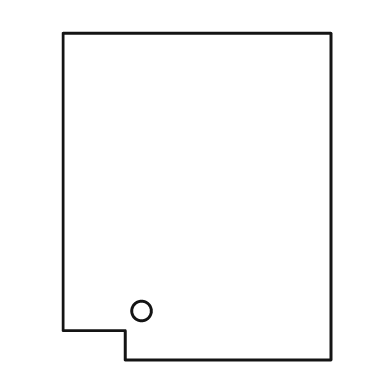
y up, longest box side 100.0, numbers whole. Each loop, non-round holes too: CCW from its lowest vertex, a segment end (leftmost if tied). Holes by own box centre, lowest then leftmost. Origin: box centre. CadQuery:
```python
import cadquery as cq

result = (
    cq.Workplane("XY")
    .moveTo(-22.0, -50.0)
    .lineTo(41.0, -50.0)
    .lineTo(41.0, 50.0)
    .lineTo(-41.0, 50.0)
    .lineTo(-41.0, -41.0)
    .lineTo(-22.0, -41.0)
    .close()
    .moveTo(-17.0, -35.0)
    .circle(3.0)
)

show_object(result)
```